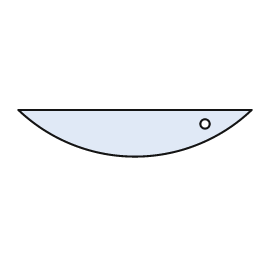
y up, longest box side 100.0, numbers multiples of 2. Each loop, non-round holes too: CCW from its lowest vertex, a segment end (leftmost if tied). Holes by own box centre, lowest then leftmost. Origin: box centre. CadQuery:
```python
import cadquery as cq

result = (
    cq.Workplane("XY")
    .moveTo(-50.0, 10.0)
    .threePointArc((0.0, -10.0), (50.0, 10.0))
    .close()
    .moveTo(30.0, 4.0)
    .circle(2.0)
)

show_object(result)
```